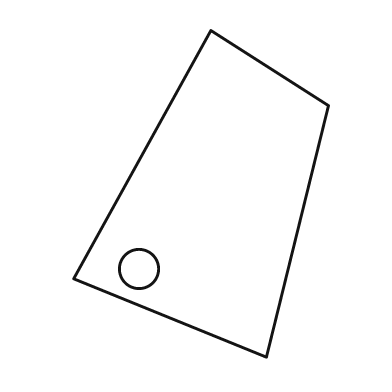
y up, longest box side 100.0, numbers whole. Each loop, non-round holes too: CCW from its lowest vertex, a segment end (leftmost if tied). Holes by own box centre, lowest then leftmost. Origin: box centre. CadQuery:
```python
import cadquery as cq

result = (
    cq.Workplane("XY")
    .moveTo(20.0, -50.0)
    .lineTo(39.0, 27.0)
    .lineTo(3.0, 50.0)
    .lineTo(-39.0, -26.0)
    .close()
    .moveTo(-19.0, -23.0)
    .circle(6.0)
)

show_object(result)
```